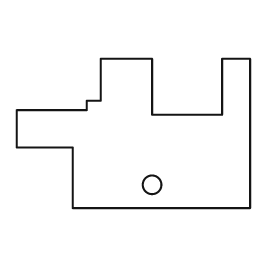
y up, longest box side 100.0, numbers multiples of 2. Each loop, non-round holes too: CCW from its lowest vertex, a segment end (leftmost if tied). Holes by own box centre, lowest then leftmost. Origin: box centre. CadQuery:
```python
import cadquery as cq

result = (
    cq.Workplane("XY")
    .moveTo(-26.0, -32.0)
    .lineTo(50.0, -32.0)
    .lineTo(50.0, 32.0)
    .lineTo(38.0, 32.0)
    .lineTo(38.0, 8.0)
    .lineTo(8.0, 8.0)
    .lineTo(8.0, 32.0)
    .lineTo(-14.0, 32.0)
    .lineTo(-14.0, 14.0)
    .lineTo(-20.0, 14.0)
    .lineTo(-20.0, 10.0)
    .lineTo(-50.0, 10.0)
    .lineTo(-50.0, -6.0)
    .lineTo(-26.0, -6.0)
    .close()
    .moveTo(8.0, -22.0)
    .circle(4.0)
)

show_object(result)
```